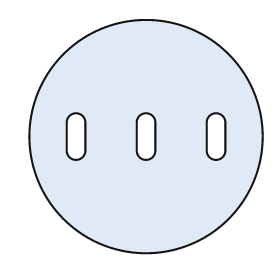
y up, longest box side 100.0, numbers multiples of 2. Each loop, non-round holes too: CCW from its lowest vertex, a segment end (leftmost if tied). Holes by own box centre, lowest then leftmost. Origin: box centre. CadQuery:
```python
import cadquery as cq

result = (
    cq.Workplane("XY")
    .moveTo(0.0, 0.0)
    .circle(50.0)
    .moveTo(-34.0, -6.0)
    .threePointArc((-30.0, -10.0), (-26.0, -6.0))
    .lineTo(-26.0, 6.0)
    .threePointArc((-30.0, 10.0), (-34.0, 6.0))
    .close()
    .moveTo(-4.0, -6.0)
    .threePointArc((0.0, -10.0), (4.0, -6.0))
    .lineTo(4.0, 6.0)
    .threePointArc((0.0, 10.0), (-4.0, 6.0))
    .close()
    .moveTo(26.0, -6.0)
    .threePointArc((30.0, -10.0), (34.0, -6.0))
    .lineTo(34.0, 6.0)
    .threePointArc((30.0, 10.0), (26.0, 6.0))
    .close()
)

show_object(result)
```